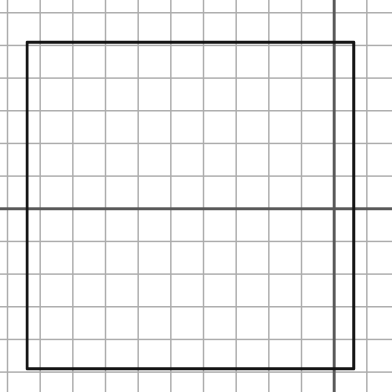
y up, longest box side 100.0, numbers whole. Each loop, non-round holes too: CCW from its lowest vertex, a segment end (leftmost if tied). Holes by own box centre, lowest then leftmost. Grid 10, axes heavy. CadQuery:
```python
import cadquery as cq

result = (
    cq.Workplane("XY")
    .moveTo(-94.0, -49.0)
    .lineTo(6.0, -49.0)
    .lineTo(6.0, 51.0)
    .lineTo(-94.0, 51.0)
    .close()
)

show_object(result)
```